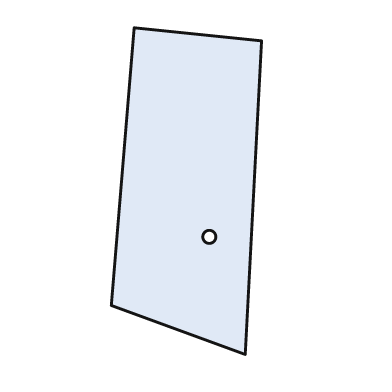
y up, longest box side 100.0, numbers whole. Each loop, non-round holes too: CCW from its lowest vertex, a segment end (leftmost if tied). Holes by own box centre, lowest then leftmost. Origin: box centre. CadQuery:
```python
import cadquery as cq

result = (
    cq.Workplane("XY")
    .moveTo(18.0, -50.0)
    .lineTo(23.0, 46.0)
    .lineTo(-16.0, 50.0)
    .lineTo(-23.0, -35.0)
    .close()
    .moveTo(7.0, -14.0)
    .circle(2.0)
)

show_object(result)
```